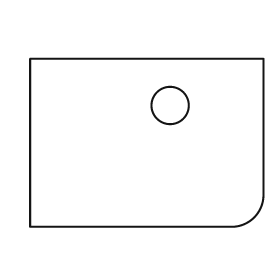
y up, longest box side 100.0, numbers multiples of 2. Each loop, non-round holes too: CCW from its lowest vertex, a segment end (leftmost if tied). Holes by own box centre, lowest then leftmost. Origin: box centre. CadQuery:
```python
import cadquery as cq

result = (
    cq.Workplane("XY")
    .moveTo(-50.0, -36.0)
    .lineTo(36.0, -36.0)
    .threePointArc((46.0, -32.0), (50.0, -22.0))
    .lineTo(50.0, 36.0)
    .lineTo(-50.0, 36.0)
    .close()
    .moveTo(10.0, 16.0)
    .circle(8.0)
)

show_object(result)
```